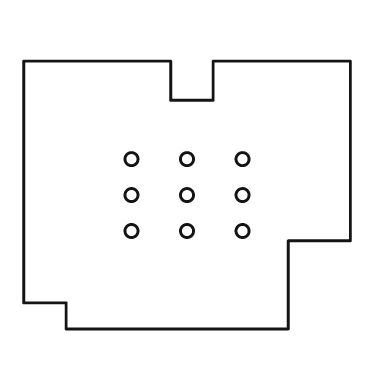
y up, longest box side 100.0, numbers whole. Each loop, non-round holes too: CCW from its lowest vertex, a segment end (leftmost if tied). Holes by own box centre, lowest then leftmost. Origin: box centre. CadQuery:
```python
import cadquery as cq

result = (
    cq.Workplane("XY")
    .moveTo(-37.0, -41.0)
    .lineTo(31.0, -41.0)
    .lineTo(31.0, -14.0)
    .lineTo(50.0, -14.0)
    .lineTo(50.0, 41.0)
    .lineTo(8.0, 41.0)
    .lineTo(8.0, 29.0)
    .lineTo(-5.0, 29.0)
    .lineTo(-5.0, 41.0)
    .lineTo(-50.0, 41.0)
    .lineTo(-50.0, -33.0)
    .lineTo(-37.0, -33.0)
    .close()
    .moveTo(-17.0, -11.0)
    .circle(2.0)
    .moveTo(0.0, -11.0)
    .circle(2.0)
    .moveTo(17.0, -11.0)
    .circle(2.0)
    .moveTo(-17.0, 0.0)
    .circle(2.0)
    .moveTo(0.0, 0.0)
    .circle(2.0)
    .moveTo(17.0, 0.0)
    .circle(2.0)
    .moveTo(-17.0, 11.0)
    .circle(2.0)
    .moveTo(0.0, 11.0)
    .circle(2.0)
    .moveTo(17.0, 11.0)
    .circle(2.0)
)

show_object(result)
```